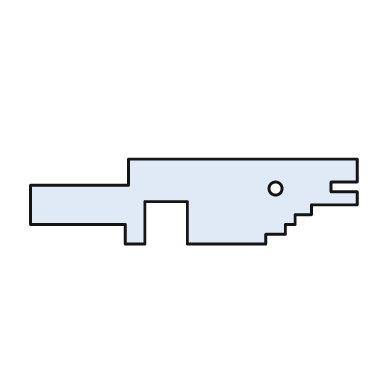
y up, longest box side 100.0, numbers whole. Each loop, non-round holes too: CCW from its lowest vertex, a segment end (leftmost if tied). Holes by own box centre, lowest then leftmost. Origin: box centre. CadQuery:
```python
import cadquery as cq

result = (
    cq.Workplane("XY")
    .moveTo(-21.0, -13.0)
    .lineTo(-15.0, -13.0)
    .lineTo(-15.0, 0.0)
    .lineTo(-2.0, 0.0)
    .lineTo(-2.0, -13.0)
    .lineTo(22.0, -13.0)
    .lineTo(22.0, -10.0)
    .lineTo(28.0, -10.0)
    .lineTo(28.0, -7.0)
    .lineTo(31.0, -7.0)
    .lineTo(31.0, -4.0)
    .lineTo(36.0, -4.0)
    .lineTo(36.0, -1.0)
    .lineTo(50.0, -1.0)
    .lineTo(50.0, 3.0)
    .lineTo(42.0, 3.0)
    .lineTo(42.0, 6.0)
    .lineTo(50.0, 6.0)
    .lineTo(50.0, 13.0)
    .lineTo(-20.0, 13.0)
    .lineTo(-20.0, 5.0)
    .lineTo(-50.0, 5.0)
    .lineTo(-50.0, -7.0)
    .lineTo(-21.0, -7.0)
    .close()
    .moveTo(25.0, 4.0)
    .circle(2.0)
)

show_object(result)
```